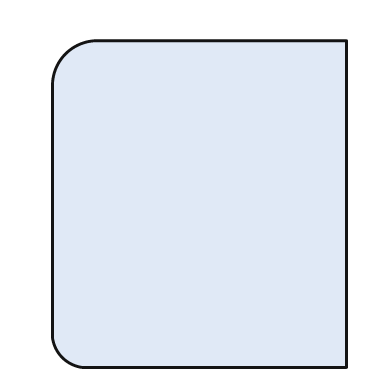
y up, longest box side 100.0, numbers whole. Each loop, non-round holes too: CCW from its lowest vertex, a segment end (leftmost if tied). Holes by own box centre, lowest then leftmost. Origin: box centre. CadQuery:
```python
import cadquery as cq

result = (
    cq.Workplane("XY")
    .moveTo(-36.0, -50.0)
    .lineTo(45.0, -50.0)
    .lineTo(45.0, 50.0)
    .lineTo(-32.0, 50.0)
    .threePointArc((-41.0, 46.0), (-45.0, 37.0))
    .lineTo(-45.0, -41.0)
    .threePointArc((-42.0, -47.0), (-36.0, -50.0))
    .close()
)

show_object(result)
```